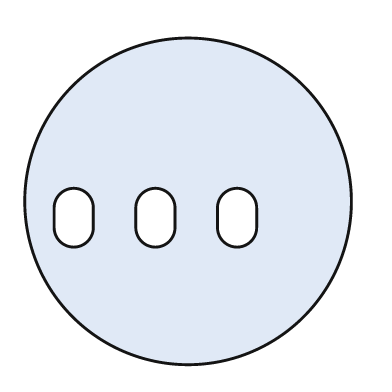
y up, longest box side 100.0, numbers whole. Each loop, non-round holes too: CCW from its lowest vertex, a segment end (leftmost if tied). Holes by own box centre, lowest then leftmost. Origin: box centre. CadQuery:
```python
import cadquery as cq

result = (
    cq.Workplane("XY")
    .moveTo(0.0, 0.0)
    .circle(50.0)
    .moveTo(-41.0, -8.0)
    .threePointArc((-35.0, -14.0), (-29.0, -8.0))
    .lineTo(-29.0, -2.0)
    .threePointArc((-35.0, 4.0), (-41.0, -2.0))
    .close()
    .moveTo(-16.0, -8.0)
    .threePointArc((-10.0, -14.0), (-4.0, -8.0))
    .lineTo(-4.0, -2.0)
    .threePointArc((-10.0, 4.0), (-16.0, -2.0))
    .close()
    .moveTo(9.0, -8.0)
    .threePointArc((15.0, -14.0), (21.0, -8.0))
    .lineTo(21.0, -2.0)
    .threePointArc((15.0, 4.0), (9.0, -2.0))
    .close()
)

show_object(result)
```